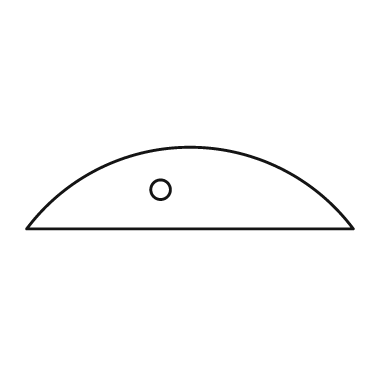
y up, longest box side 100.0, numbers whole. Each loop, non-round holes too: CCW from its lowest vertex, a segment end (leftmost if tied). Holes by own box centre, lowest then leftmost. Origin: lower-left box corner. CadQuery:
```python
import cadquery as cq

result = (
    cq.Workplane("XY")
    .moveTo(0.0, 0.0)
    .lineTo(100.0, 0.0)
    .threePointArc((50.0, 25.0), (0.0, 0.0))
    .close()
    .moveTo(41.0, 12.0)
    .circle(3.0)
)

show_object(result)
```